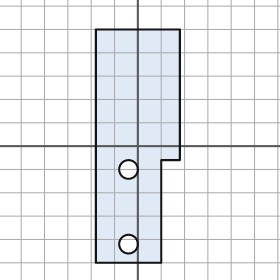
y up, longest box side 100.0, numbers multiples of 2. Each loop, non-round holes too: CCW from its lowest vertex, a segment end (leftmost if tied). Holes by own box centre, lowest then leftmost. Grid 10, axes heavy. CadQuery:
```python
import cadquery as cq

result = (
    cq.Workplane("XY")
    .moveTo(-18.0, -50.0)
    .lineTo(10.0, -50.0)
    .lineTo(10.0, -6.0)
    .lineTo(18.0, -6.0)
    .lineTo(18.0, 50.0)
    .lineTo(-18.0, 50.0)
    .close()
    .moveTo(-4.0, -42.0)
    .circle(4.0)
    .moveTo(-4.0, -10.0)
    .circle(4.0)
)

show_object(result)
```